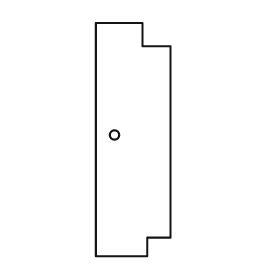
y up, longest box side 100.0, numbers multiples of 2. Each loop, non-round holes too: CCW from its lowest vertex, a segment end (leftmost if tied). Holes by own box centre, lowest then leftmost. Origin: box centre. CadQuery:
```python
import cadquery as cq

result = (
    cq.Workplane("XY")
    .moveTo(-16.0, -50.0)
    .lineTo(6.0, -50.0)
    .lineTo(6.0, -42.0)
    .lineTo(16.0, -42.0)
    .lineTo(16.0, 40.0)
    .lineTo(4.0, 40.0)
    .lineTo(4.0, 50.0)
    .lineTo(-16.0, 50.0)
    .close()
    .moveTo(-8.0, 2.0)
    .circle(2.0)
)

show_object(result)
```